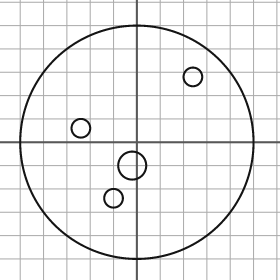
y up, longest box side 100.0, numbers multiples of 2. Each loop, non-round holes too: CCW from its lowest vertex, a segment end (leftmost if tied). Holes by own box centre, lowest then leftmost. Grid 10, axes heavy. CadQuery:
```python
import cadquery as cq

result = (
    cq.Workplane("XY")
    .moveTo(0.0, 0.0)
    .circle(50.0)
    .moveTo(-10.0, -24.0)
    .circle(4.0)
    .moveTo(-2.0, -10.0)
    .circle(6.0)
    .moveTo(-24.0, 6.0)
    .circle(4.0)
    .moveTo(24.0, 28.0)
    .circle(4.0)
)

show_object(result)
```